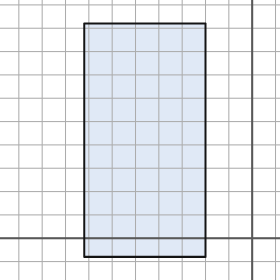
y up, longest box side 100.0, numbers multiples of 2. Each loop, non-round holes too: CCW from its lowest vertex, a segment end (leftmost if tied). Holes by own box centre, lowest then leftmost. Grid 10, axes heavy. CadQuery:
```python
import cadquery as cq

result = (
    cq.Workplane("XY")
    .moveTo(-72.0, -8.0)
    .lineTo(-20.0, -8.0)
    .lineTo(-20.0, 92.0)
    .lineTo(-72.0, 92.0)
    .close()
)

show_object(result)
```